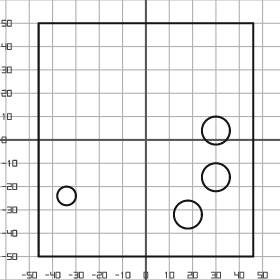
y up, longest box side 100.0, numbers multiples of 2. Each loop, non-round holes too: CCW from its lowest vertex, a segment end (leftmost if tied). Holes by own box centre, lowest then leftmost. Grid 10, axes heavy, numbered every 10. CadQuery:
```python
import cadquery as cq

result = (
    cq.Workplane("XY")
    .moveTo(-46.0, -50.0)
    .lineTo(46.0, -50.0)
    .lineTo(46.0, 50.0)
    .lineTo(-46.0, 50.0)
    .close()
    .moveTo(18.0, -32.0)
    .circle(6.0)
    .moveTo(-34.0, -24.0)
    .circle(4.0)
    .moveTo(30.0, -16.0)
    .circle(6.0)
    .moveTo(30.0, 4.0)
    .circle(6.0)
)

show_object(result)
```